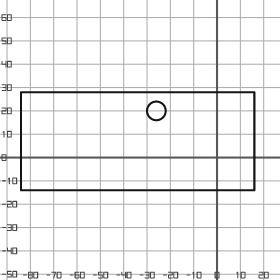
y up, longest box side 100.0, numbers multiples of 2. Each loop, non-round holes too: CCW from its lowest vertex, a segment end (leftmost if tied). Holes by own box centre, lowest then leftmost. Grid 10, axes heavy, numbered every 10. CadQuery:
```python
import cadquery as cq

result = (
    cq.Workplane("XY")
    .moveTo(-84.0, -14.0)
    .lineTo(16.0, -14.0)
    .lineTo(16.0, 28.0)
    .lineTo(-84.0, 28.0)
    .close()
    .moveTo(-26.0, 20.0)
    .circle(4.0)
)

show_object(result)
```